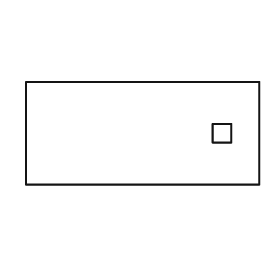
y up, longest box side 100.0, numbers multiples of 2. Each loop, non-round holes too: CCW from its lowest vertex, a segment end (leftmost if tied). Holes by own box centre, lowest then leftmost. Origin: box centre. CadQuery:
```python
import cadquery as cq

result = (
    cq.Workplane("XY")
    .moveTo(-50.0, -22.0)
    .lineTo(50.0, -22.0)
    .lineTo(50.0, 22.0)
    .lineTo(-50.0, 22.0)
    .close()
    .moveTo(30.0, -4.0)
    .lineTo(38.0, -4.0)
    .lineTo(38.0, 4.0)
    .lineTo(30.0, 4.0)
    .close()
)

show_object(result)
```